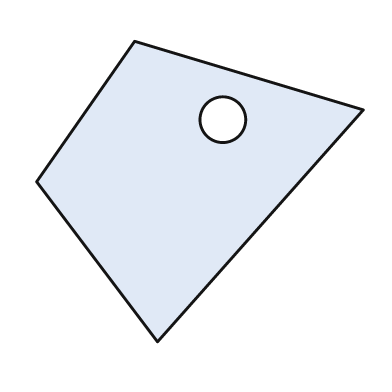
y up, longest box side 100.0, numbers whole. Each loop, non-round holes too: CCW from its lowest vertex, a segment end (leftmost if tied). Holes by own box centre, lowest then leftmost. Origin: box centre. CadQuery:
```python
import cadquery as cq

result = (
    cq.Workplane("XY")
    .moveTo(-13.0, -46.0)
    .lineTo(50.0, 25.0)
    .lineTo(-20.0, 46.0)
    .lineTo(-50.0, 3.0)
    .close()
    .moveTo(7.0, 22.0)
    .circle(7.0)
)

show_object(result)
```